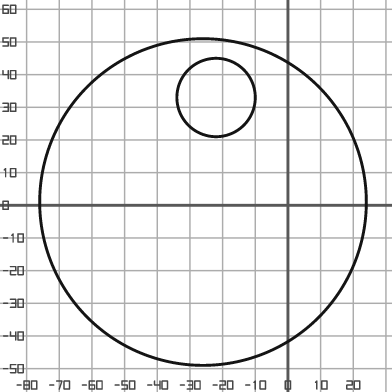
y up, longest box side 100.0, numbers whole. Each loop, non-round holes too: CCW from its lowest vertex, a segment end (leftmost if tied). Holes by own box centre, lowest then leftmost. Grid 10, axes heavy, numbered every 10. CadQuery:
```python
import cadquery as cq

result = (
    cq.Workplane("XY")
    .moveTo(-26.0, 1.0)
    .circle(50.0)
    .moveTo(-22.0, 33.0)
    .circle(12.0)
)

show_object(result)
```